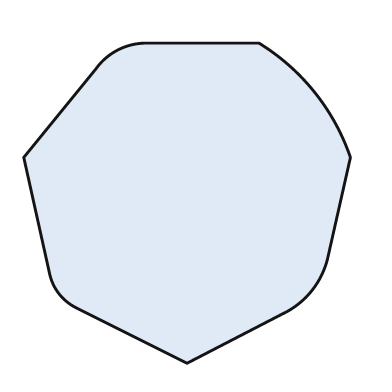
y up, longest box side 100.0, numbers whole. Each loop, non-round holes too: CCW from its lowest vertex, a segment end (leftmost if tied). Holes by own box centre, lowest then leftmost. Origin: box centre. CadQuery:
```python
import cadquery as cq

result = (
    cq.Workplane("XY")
    .moveTo(0.0, -49.0)
    .lineTo(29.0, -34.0)
    .threePointArc((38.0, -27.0), (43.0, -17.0))
    .lineTo(50.0, 14.0)
    .threePointArc((39.0, 34.0), (22.0, 49.0))
    .lineTo(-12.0, 49.0)
    .threePointArc((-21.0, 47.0), (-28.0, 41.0))
    .lineTo(-50.0, 14.0)
    .lineTo(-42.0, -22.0)
    .threePointArc((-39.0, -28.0), (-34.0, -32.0))
    .close()
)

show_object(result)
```